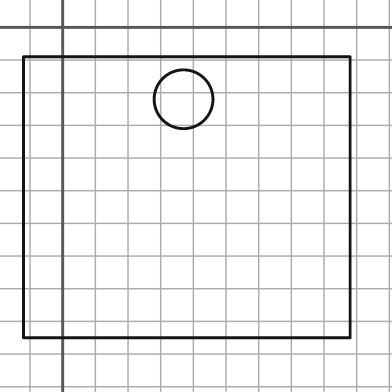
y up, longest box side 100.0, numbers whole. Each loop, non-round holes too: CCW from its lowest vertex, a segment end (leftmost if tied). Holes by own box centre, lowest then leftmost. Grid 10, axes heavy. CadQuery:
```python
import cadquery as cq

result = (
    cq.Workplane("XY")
    .moveTo(-12.0, -95.0)
    .lineTo(88.0, -95.0)
    .lineTo(88.0, -9.0)
    .lineTo(-12.0, -9.0)
    .close()
    .moveTo(37.0, -22.0)
    .circle(9.0)
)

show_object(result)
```